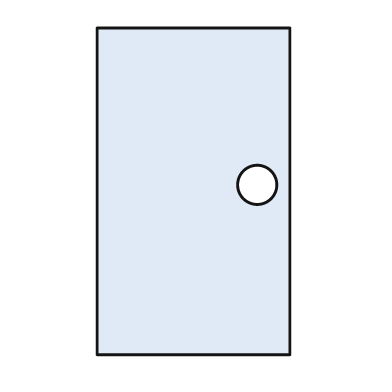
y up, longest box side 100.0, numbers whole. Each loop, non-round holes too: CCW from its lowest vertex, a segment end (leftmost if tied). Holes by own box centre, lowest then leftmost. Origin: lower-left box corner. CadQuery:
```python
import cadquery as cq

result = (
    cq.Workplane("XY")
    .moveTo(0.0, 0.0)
    .lineTo(59.0, 0.0)
    .lineTo(59.0, 100.0)
    .lineTo(0.0, 100.0)
    .close()
    .moveTo(49.0, 52.0)
    .circle(6.0)
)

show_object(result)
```